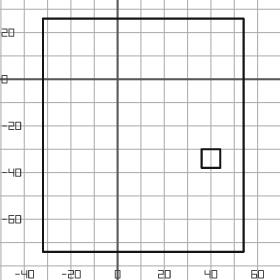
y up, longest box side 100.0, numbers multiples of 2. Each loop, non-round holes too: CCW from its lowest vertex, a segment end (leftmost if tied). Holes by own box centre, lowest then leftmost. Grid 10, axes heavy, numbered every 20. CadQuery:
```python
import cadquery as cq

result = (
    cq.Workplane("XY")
    .moveTo(-32.0, -74.0)
    .lineTo(54.0, -74.0)
    .lineTo(54.0, 26.0)
    .lineTo(-32.0, 26.0)
    .close()
    .moveTo(36.0, -38.0)
    .lineTo(44.0, -38.0)
    .lineTo(44.0, -30.0)
    .lineTo(36.0, -30.0)
    .close()
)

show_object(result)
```